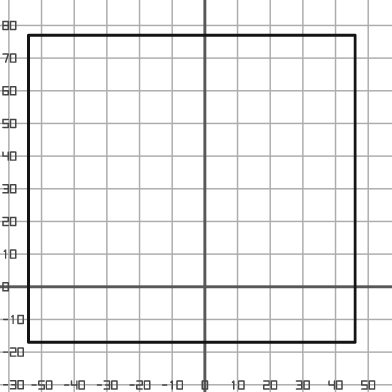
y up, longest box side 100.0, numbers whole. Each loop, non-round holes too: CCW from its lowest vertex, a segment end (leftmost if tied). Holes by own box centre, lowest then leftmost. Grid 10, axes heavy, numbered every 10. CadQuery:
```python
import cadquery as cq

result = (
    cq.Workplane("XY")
    .moveTo(-54.0, -17.0)
    .lineTo(46.0, -17.0)
    .lineTo(46.0, 77.0)
    .lineTo(-54.0, 77.0)
    .close()
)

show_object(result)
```